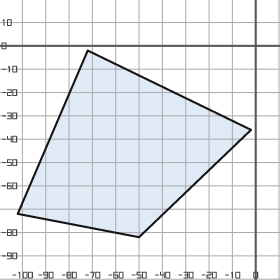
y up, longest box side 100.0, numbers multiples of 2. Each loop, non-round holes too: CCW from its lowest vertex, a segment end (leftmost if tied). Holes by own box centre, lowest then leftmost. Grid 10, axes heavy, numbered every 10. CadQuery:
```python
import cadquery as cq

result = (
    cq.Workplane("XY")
    .moveTo(-50.0, -82.0)
    .lineTo(-2.0, -36.0)
    .lineTo(-72.0, -2.0)
    .lineTo(-102.0, -72.0)
    .close()
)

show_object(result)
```